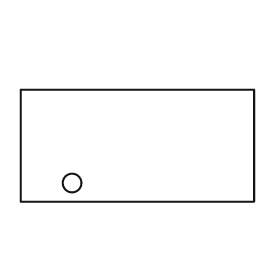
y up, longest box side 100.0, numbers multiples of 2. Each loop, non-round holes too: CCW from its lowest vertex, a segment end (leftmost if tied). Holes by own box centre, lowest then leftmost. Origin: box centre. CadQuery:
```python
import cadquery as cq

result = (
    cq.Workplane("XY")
    .moveTo(-50.0, -24.0)
    .lineTo(50.0, -24.0)
    .lineTo(50.0, 24.0)
    .lineTo(-50.0, 24.0)
    .close()
    .moveTo(-28.0, -16.0)
    .circle(4.0)
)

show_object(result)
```